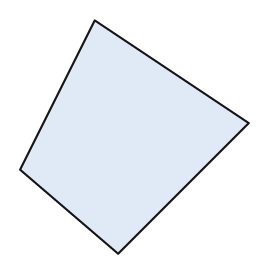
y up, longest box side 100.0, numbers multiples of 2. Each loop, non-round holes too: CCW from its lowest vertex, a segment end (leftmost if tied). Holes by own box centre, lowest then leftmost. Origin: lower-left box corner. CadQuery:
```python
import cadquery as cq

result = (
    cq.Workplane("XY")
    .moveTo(42.0, 0.0)
    .lineTo(98.0, 56.0)
    .lineTo(32.0, 100.0)
    .lineTo(0.0, 36.0)
    .close()
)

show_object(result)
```